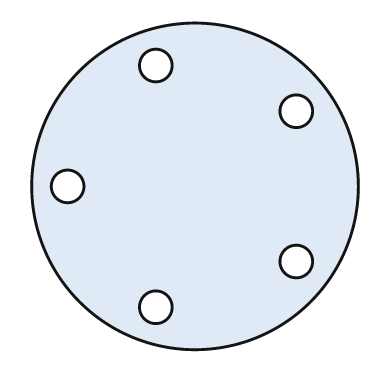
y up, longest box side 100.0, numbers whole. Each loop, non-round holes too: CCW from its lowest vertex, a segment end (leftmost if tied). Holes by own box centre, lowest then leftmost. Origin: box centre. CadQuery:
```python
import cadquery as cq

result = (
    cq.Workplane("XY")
    .moveTo(0.0, 0.0)
    .circle(50.0)
    .moveTo(-12.0, -37.0)
    .circle(5.0)
    .moveTo(31.0, -23.0)
    .circle(5.0)
    .moveTo(-39.0, 0.0)
    .circle(5.0)
    .moveTo(31.0, 23.0)
    .circle(5.0)
    .moveTo(-12.0, 37.0)
    .circle(5.0)
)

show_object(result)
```